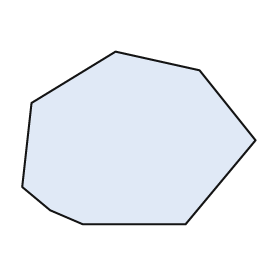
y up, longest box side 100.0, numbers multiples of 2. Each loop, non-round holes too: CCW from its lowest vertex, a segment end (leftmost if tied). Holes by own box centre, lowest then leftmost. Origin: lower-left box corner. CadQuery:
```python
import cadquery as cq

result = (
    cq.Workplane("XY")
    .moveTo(26.0, 0.0)
    .lineTo(70.0, 0.0)
    .lineTo(100.0, 36.0)
    .lineTo(76.0, 66.0)
    .lineTo(40.0, 74.0)
    .lineTo(4.0, 52.0)
    .lineTo(0.0, 16.0)
    .lineTo(12.0, 6.0)
    .close()
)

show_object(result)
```